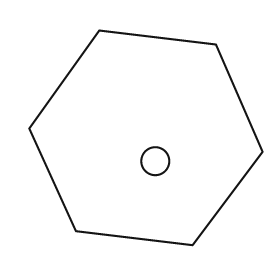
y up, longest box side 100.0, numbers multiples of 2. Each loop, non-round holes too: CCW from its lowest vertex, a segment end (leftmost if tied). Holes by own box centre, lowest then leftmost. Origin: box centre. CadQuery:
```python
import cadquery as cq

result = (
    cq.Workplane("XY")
    .moveTo(20.0, -46.0)
    .lineTo(50.0, -6.0)
    .lineTo(30.0, 40.0)
    .lineTo(-20.0, 46.0)
    .lineTo(-50.0, 4.0)
    .lineTo(-30.0, -40.0)
    .close()
    .moveTo(4.0, -10.0)
    .circle(6.0)
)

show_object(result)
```